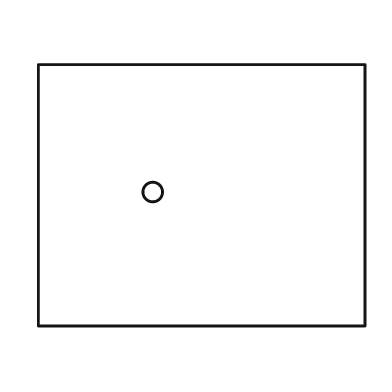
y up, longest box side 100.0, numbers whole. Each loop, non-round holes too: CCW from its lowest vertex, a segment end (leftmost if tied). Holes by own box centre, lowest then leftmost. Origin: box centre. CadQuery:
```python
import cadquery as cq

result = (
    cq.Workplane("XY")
    .moveTo(-50.0, -40.0)
    .lineTo(50.0, -40.0)
    .lineTo(50.0, 40.0)
    .lineTo(-50.0, 40.0)
    .close()
    .moveTo(-15.0, 1.0)
    .circle(3.0)
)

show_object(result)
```